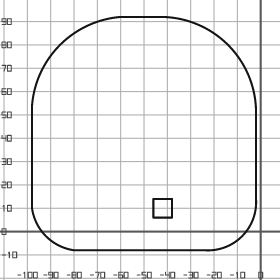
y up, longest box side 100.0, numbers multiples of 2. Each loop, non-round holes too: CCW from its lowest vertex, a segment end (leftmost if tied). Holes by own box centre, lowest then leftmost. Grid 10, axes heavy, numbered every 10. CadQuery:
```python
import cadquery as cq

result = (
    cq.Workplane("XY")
    .moveTo(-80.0, -8.0)
    .lineTo(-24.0, -8.0)
    .threePointArc((-8.0, -2.0), (-2.0, 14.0))
    .lineTo(-2.0, 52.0)
    .threePointArc((-14.0, 80.0), (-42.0, 92.0))
    .lineTo(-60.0, 92.0)
    .threePointArc((-86.0, 80.0), (-98.0, 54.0))
    .lineTo(-98.0, 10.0)
    .threePointArc((-92.0, -2.0), (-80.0, -8.0))
    .close()
    .moveTo(-46.0, 6.0)
    .lineTo(-38.0, 6.0)
    .lineTo(-38.0, 14.0)
    .lineTo(-46.0, 14.0)
    .close()
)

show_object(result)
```